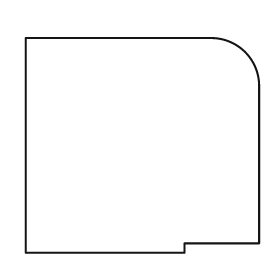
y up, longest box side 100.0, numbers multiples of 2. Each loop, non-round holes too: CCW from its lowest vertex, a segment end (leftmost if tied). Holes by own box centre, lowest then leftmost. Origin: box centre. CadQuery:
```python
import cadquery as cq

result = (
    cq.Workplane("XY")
    .moveTo(-50.0, -46.0)
    .lineTo(18.0, -46.0)
    .lineTo(18.0, -42.0)
    .lineTo(50.0, -42.0)
    .lineTo(50.0, 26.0)
    .threePointArc((44.0, 40.0), (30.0, 46.0))
    .lineTo(-50.0, 46.0)
    .close()
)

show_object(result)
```